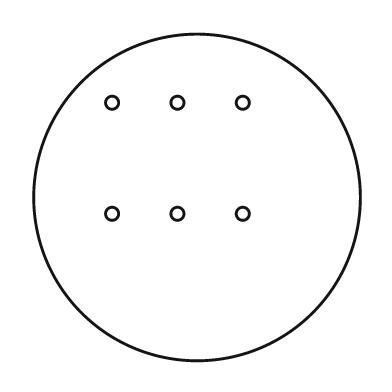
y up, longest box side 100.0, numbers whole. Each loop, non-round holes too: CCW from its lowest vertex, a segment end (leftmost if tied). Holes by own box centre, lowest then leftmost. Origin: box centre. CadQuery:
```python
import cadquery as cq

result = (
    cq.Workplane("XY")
    .moveTo(0.0, 0.0)
    .circle(50.0)
    .moveTo(-26.0, -5.0)
    .circle(2.0)
    .moveTo(-6.0, -5.0)
    .circle(2.0)
    .moveTo(14.0, -5.0)
    .circle(2.0)
    .moveTo(-26.0, 29.0)
    .circle(2.0)
    .moveTo(-6.0, 29.0)
    .circle(2.0)
    .moveTo(14.0, 29.0)
    .circle(2.0)
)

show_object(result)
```